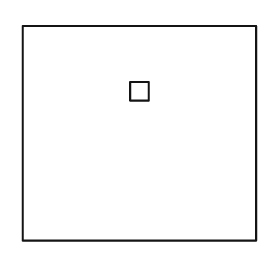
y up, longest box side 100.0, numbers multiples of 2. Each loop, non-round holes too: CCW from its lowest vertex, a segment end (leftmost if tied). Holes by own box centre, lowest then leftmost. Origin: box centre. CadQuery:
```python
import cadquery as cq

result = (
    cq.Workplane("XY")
    .moveTo(-50.0, -46.0)
    .lineTo(50.0, -46.0)
    .lineTo(50.0, 46.0)
    .lineTo(-50.0, 46.0)
    .close()
    .moveTo(-4.0, 14.0)
    .lineTo(4.0, 14.0)
    .lineTo(4.0, 22.0)
    .lineTo(-4.0, 22.0)
    .close()
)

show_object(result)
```